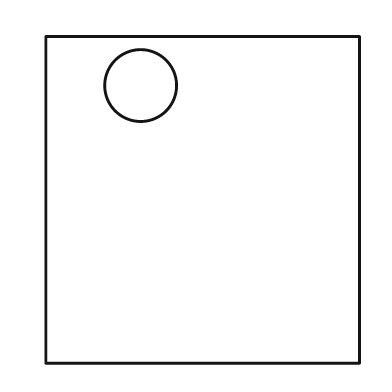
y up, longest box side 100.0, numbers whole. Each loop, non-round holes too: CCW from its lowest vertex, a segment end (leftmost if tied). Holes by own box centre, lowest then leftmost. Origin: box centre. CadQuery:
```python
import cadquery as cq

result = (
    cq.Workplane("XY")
    .moveTo(-48.0, -50.0)
    .lineTo(48.0, -50.0)
    .lineTo(48.0, 50.0)
    .lineTo(-48.0, 50.0)
    .close()
    .moveTo(-19.0, 35.0)
    .circle(11.0)
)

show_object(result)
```